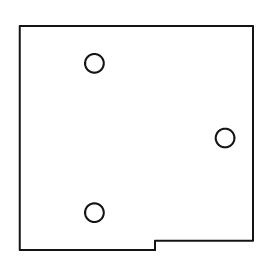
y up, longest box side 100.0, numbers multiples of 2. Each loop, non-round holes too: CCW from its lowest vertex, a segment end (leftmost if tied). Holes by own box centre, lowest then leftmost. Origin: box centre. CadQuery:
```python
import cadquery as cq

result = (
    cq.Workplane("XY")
    .moveTo(-50.0, -48.0)
    .lineTo(8.0, -48.0)
    .lineTo(8.0, -44.0)
    .lineTo(50.0, -44.0)
    .lineTo(50.0, 48.0)
    .lineTo(-50.0, 48.0)
    .close()
    .moveTo(-18.0, -32.0)
    .circle(4.0)
    .moveTo(38.0, 0.0)
    .circle(4.0)
    .moveTo(-18.0, 32.0)
    .circle(4.0)
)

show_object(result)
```